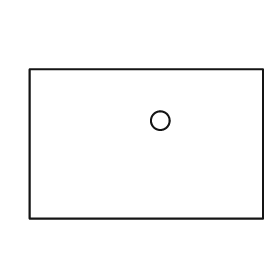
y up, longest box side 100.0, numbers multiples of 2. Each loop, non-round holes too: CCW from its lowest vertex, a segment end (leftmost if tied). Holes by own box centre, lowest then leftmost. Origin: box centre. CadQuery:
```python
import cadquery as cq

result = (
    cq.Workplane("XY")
    .moveTo(-50.0, -32.0)
    .lineTo(50.0, -32.0)
    .lineTo(50.0, 32.0)
    .lineTo(-50.0, 32.0)
    .close()
    .moveTo(6.0, 10.0)
    .circle(4.0)
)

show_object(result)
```